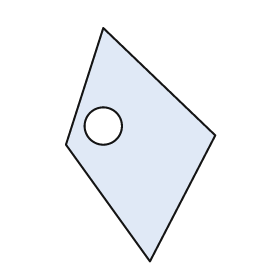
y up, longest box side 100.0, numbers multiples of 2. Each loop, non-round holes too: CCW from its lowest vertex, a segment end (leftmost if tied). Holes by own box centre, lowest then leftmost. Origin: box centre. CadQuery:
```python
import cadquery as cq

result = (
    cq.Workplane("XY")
    .moveTo(4.0, -50.0)
    .lineTo(32.0, 4.0)
    .lineTo(-16.0, 50.0)
    .lineTo(-32.0, 0.0)
    .close()
    .moveTo(-16.0, 8.0)
    .circle(8.0)
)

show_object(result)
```